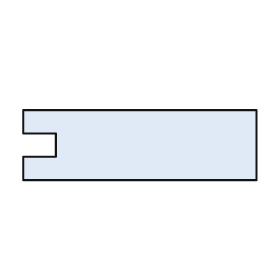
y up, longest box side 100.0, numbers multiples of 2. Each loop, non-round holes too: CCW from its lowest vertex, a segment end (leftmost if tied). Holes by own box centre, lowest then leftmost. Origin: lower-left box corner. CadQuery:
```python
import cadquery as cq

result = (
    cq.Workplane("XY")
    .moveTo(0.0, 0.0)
    .lineTo(100.0, 0.0)
    .lineTo(100.0, 30.0)
    .lineTo(0.0, 30.0)
    .lineTo(0.0, 20.0)
    .lineTo(14.0, 20.0)
    .lineTo(14.0, 10.0)
    .lineTo(0.0, 10.0)
    .close()
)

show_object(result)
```